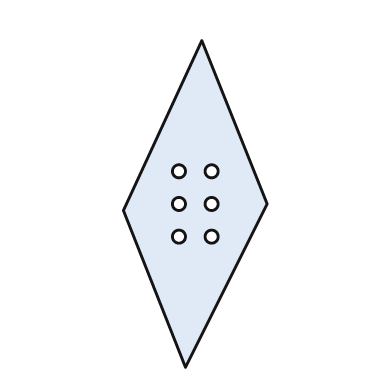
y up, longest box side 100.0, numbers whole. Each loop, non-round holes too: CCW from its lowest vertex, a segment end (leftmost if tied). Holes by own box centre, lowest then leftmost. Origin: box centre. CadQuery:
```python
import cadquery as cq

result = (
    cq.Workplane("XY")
    .moveTo(-3.0, -50.0)
    .lineTo(22.0, 0.0)
    .lineTo(2.0, 50.0)
    .lineTo(-22.0, -2.0)
    .close()
    .moveTo(-5.0, -10.0)
    .circle(2.0)
    .moveTo(5.0, -10.0)
    .circle(2.0)
    .moveTo(-5.0, 0.0)
    .circle(2.0)
    .moveTo(5.0, 0.0)
    .circle(2.0)
    .moveTo(-5.0, 10.0)
    .circle(2.0)
    .moveTo(5.0, 10.0)
    .circle(2.0)
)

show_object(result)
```